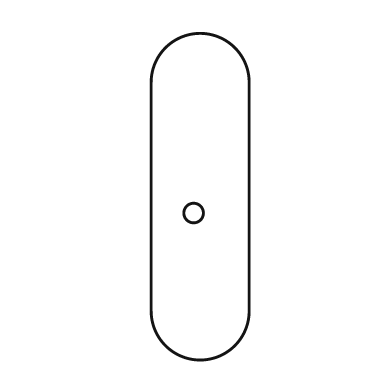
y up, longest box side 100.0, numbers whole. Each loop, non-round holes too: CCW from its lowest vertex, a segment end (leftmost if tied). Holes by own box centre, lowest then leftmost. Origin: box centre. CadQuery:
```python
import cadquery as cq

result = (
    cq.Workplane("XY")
    .moveTo(-15.0, -35.0)
    .threePointArc((0.0, -50.0), (15.0, -35.0))
    .lineTo(15.0, 35.0)
    .threePointArc((0.0, 50.0), (-15.0, 35.0))
    .close()
    .moveTo(-2.0, -5.0)
    .circle(3.0)
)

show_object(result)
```